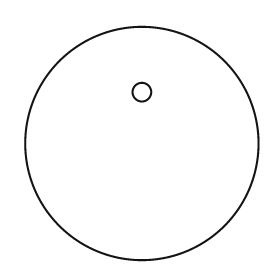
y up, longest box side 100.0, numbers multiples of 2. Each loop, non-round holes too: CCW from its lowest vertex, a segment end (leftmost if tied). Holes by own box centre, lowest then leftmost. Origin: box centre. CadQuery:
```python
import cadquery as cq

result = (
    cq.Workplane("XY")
    .moveTo(0.0, 0.0)
    .circle(50.0)
    .moveTo(0.0, 22.0)
    .circle(4.0)
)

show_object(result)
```